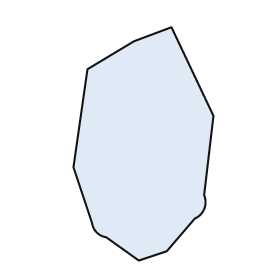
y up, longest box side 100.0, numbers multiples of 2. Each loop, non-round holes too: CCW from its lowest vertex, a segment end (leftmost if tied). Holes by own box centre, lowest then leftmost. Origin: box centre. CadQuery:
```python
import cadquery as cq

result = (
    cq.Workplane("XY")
    .moveTo(-2.0, -50.0)
    .lineTo(10.0, -46.0)
    .lineTo(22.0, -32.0)
    .threePointArc((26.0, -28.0), (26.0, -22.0))
    .lineTo(30.0, 12.0)
    .lineTo(12.0, 50.0)
    .lineTo(-4.0, 44.0)
    .lineTo(-24.0, 32.0)
    .lineTo(-30.0, -10.0)
    .lineTo(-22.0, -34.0)
    .threePointArc((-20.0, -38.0), (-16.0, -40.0))
    .close()
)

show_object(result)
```